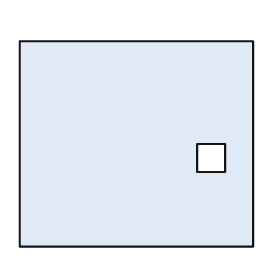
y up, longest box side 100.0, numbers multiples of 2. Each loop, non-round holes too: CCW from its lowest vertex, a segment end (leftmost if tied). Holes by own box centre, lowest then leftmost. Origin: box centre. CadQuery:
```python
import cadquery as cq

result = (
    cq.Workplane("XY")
    .moveTo(-50.0, -44.0)
    .lineTo(50.0, -44.0)
    .lineTo(50.0, 44.0)
    .lineTo(-50.0, 44.0)
    .close()
    .moveTo(26.0, -12.0)
    .lineTo(38.0, -12.0)
    .lineTo(38.0, 0.0)
    .lineTo(26.0, 0.0)
    .close()
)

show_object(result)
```